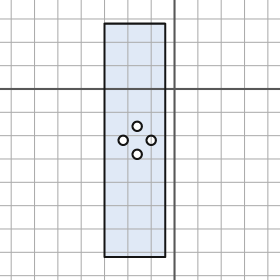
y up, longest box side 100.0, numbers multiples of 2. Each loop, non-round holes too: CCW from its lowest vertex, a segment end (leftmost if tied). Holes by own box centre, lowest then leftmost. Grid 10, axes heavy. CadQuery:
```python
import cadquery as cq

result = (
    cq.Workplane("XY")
    .moveTo(-30.0, -72.0)
    .lineTo(-4.0, -72.0)
    .lineTo(-4.0, 28.0)
    .lineTo(-30.0, 28.0)
    .close()
    .moveTo(-16.0, -28.0)
    .circle(2.0)
    .moveTo(-22.0, -22.0)
    .circle(2.0)
    .moveTo(-10.0, -22.0)
    .circle(2.0)
    .moveTo(-16.0, -16.0)
    .circle(2.0)
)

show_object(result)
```